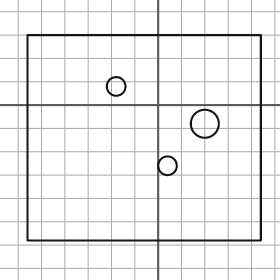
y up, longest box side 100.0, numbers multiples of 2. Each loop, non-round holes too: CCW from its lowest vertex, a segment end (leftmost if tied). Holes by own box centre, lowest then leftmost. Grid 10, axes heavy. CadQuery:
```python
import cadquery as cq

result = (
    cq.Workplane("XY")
    .moveTo(-56.0, -58.0)
    .lineTo(44.0, -58.0)
    .lineTo(44.0, 30.0)
    .lineTo(-56.0, 30.0)
    .close()
    .moveTo(4.0, -26.0)
    .circle(4.0)
    .moveTo(20.0, -8.0)
    .circle(6.0)
    .moveTo(-18.0, 8.0)
    .circle(4.0)
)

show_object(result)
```